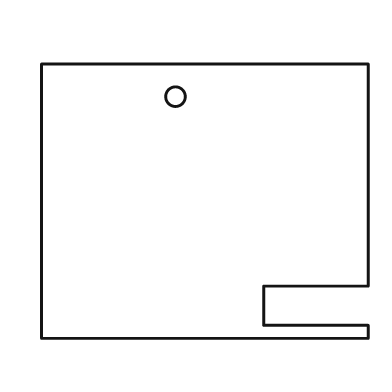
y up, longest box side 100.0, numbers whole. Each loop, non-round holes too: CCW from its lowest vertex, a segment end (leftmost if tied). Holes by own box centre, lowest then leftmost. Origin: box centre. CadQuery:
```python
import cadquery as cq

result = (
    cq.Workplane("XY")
    .moveTo(-50.0, -42.0)
    .lineTo(50.0, -42.0)
    .lineTo(50.0, -38.0)
    .lineTo(18.0, -38.0)
    .lineTo(18.0, -26.0)
    .lineTo(50.0, -26.0)
    .lineTo(50.0, 42.0)
    .lineTo(-50.0, 42.0)
    .close()
    .moveTo(-9.0, 32.0)
    .circle(3.0)
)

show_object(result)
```